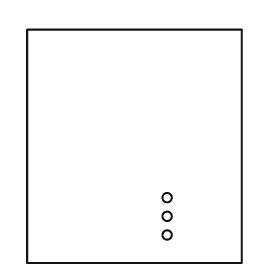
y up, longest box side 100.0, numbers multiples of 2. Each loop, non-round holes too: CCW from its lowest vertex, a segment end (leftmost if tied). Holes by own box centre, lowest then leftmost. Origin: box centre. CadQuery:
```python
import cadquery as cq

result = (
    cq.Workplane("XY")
    .moveTo(-46.0, -50.0)
    .lineTo(46.0, -50.0)
    .lineTo(46.0, 50.0)
    .lineTo(-46.0, 50.0)
    .close()
    .moveTo(14.0, -38.0)
    .circle(2.0)
    .moveTo(14.0, -30.0)
    .circle(2.0)
    .moveTo(14.0, -22.0)
    .circle(2.0)
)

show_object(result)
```